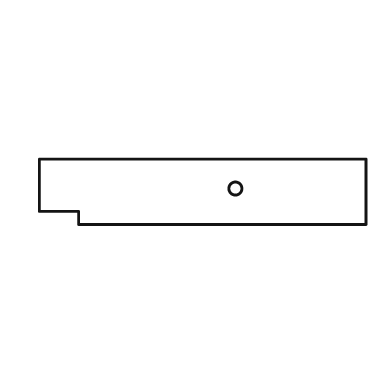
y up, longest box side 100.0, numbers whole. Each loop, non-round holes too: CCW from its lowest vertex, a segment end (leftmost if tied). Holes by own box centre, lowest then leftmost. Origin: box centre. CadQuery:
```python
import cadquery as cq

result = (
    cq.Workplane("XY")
    .moveTo(-38.0, -10.0)
    .lineTo(50.0, -10.0)
    .lineTo(50.0, 10.0)
    .lineTo(-50.0, 10.0)
    .lineTo(-50.0, -6.0)
    .lineTo(-38.0, -6.0)
    .close()
    .moveTo(10.0, 1.0)
    .circle(2.0)
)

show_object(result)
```